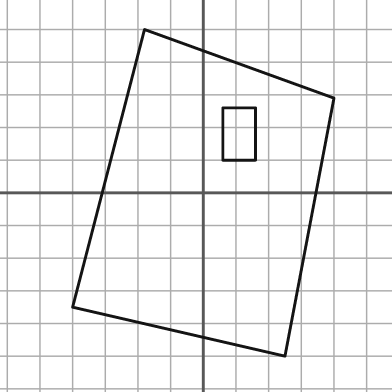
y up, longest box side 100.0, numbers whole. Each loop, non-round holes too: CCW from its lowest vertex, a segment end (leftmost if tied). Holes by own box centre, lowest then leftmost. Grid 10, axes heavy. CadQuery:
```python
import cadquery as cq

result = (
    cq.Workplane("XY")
    .moveTo(25.0, -50.0)
    .lineTo(40.0, 29.0)
    .lineTo(-18.0, 50.0)
    .lineTo(-40.0, -35.0)
    .close()
    .moveTo(6.0, 10.0)
    .lineTo(16.0, 10.0)
    .lineTo(16.0, 26.0)
    .lineTo(6.0, 26.0)
    .close()
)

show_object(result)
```